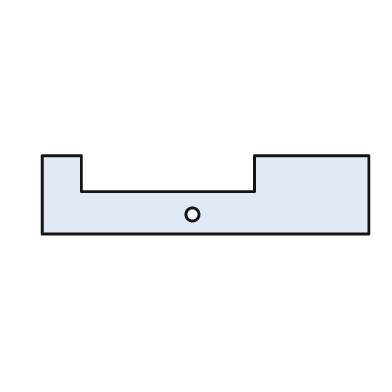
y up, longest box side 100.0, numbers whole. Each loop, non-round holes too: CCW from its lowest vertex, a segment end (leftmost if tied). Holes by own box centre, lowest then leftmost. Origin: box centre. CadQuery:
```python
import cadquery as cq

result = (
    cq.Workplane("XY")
    .moveTo(-50.0, -12.0)
    .lineTo(50.0, -12.0)
    .lineTo(50.0, 12.0)
    .lineTo(15.0, 12.0)
    .lineTo(15.0, 1.0)
    .lineTo(-38.0, 1.0)
    .lineTo(-38.0, 12.0)
    .lineTo(-50.0, 12.0)
    .close()
    .moveTo(-4.0, -6.0)
    .circle(2.0)
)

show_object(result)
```